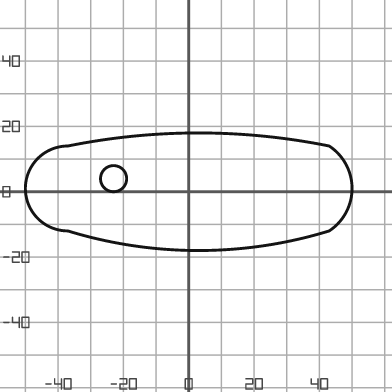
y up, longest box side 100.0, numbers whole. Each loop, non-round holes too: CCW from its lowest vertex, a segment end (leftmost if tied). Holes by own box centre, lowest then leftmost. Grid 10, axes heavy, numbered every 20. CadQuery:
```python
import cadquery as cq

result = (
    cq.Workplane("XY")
    .moveTo(-37.0, -12.0)
    .threePointArc((3.0, -18.0), (43.0, -12.0))
    .threePointArc((50.0, 1.0), (43.0, 14.0))
    .threePointArc((3.0, 18.0), (-37.0, 14.0))
    .threePointArc((-50.0, 1.0), (-37.0, -12.0))
    .close()
    .moveTo(-23.0, 4.0)
    .circle(4.0)
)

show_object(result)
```